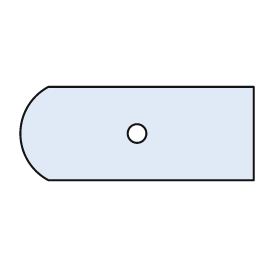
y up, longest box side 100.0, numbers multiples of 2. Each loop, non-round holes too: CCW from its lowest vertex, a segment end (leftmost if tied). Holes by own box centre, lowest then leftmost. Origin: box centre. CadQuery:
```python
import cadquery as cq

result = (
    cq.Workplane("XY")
    .moveTo(-38.0, -20.0)
    .lineTo(50.0, -20.0)
    .lineTo(50.0, 20.0)
    .lineTo(-38.0, 20.0)
    .threePointArc((-50.0, 0.0), (-38.0, -20.0))
    .close()
    .moveTo(0.0, 0.0)
    .circle(4.0)
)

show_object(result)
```